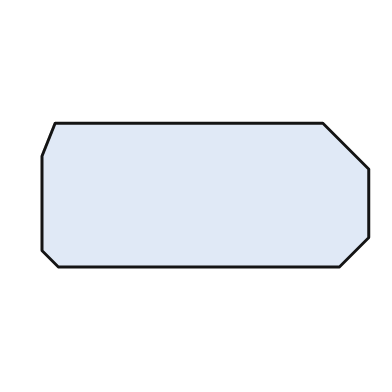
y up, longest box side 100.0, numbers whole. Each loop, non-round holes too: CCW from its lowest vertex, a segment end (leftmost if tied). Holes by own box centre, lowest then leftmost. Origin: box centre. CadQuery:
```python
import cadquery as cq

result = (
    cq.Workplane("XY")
    .moveTo(-45.0, -22.0)
    .lineTo(41.0, -22.0)
    .lineTo(50.0, -13.0)
    .lineTo(50.0, 8.0)
    .lineTo(36.0, 22.0)
    .lineTo(-46.0, 22.0)
    .lineTo(-50.0, 12.0)
    .lineTo(-50.0, -17.0)
    .close()
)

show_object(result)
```